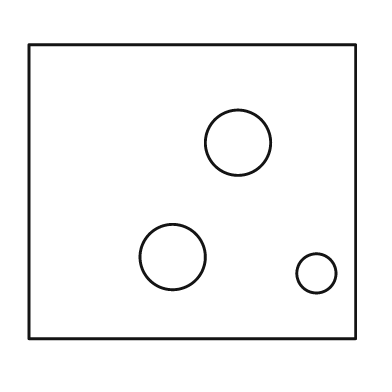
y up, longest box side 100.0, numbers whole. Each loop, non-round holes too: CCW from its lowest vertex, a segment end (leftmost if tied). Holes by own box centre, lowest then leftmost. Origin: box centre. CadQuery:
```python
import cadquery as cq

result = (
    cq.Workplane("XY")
    .moveTo(-50.0, -45.0)
    .lineTo(50.0, -45.0)
    .lineTo(50.0, 45.0)
    .lineTo(-50.0, 45.0)
    .close()
    .moveTo(38.0, -25.0)
    .circle(6.0)
    .moveTo(-6.0, -20.0)
    .circle(10.0)
    .moveTo(14.0, 15.0)
    .circle(10.0)
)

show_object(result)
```